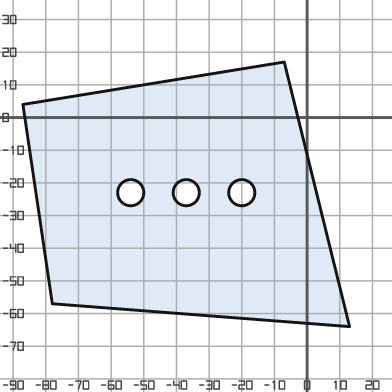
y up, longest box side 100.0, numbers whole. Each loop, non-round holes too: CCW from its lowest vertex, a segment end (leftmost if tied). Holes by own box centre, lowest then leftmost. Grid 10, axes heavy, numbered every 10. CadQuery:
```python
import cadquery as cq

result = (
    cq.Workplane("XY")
    .moveTo(13.0, -64.0)
    .lineTo(-7.0, 17.0)
    .lineTo(-87.0, 4.0)
    .lineTo(-78.0, -57.0)
    .close()
    .moveTo(-54.0, -23.0)
    .circle(4.0)
    .moveTo(-37.0, -23.0)
    .circle(4.0)
    .moveTo(-20.0, -23.0)
    .circle(4.0)
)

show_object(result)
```